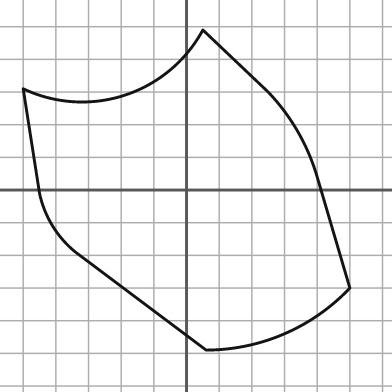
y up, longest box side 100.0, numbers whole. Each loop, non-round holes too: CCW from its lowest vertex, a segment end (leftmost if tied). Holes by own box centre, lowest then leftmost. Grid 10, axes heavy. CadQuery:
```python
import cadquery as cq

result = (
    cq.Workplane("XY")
    .moveTo(6.0, -49.0)
    .threePointArc((30.0, -44.0), (50.0, -30.0))
    .lineTo(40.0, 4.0)
    .threePointArc((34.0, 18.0), (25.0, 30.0))
    .lineTo(5.0, 49.0)
    .threePointArc((-19.0, 29.0), (-50.0, 31.0))
    .lineTo(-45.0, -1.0)
    .threePointArc((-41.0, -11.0), (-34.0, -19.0))
    .close()
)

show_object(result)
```